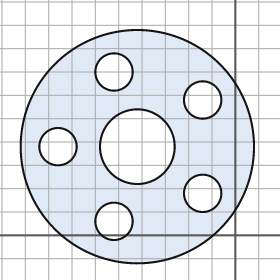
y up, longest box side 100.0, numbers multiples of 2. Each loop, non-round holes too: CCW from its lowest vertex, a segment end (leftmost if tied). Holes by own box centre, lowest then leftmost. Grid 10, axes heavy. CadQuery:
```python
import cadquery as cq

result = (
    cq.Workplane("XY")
    .moveTo(-42.0, 38.0)
    .circle(50.0)
    .moveTo(-52.0, 6.0)
    .circle(8.0)
    .moveTo(-14.0, 18.0)
    .circle(8.0)
    .moveTo(-76.0, 38.0)
    .circle(8.0)
    .moveTo(-42.0, 38.0)
    .circle(16.0)
    .moveTo(-14.0, 58.0)
    .circle(8.0)
    .moveTo(-52.0, 70.0)
    .circle(8.0)
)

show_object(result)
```